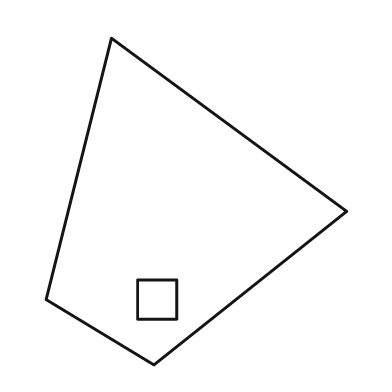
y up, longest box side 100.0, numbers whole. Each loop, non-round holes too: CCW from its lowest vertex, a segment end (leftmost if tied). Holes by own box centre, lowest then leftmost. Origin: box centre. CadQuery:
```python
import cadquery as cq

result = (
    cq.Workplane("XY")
    .moveTo(-13.0, -50.0)
    .lineTo(46.0, -3.0)
    .lineTo(-26.0, 50.0)
    .lineTo(-46.0, -30.0)
    .close()
    .moveTo(-18.0, -36.0)
    .lineTo(-6.0, -36.0)
    .lineTo(-6.0, -24.0)
    .lineTo(-18.0, -24.0)
    .close()
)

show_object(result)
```